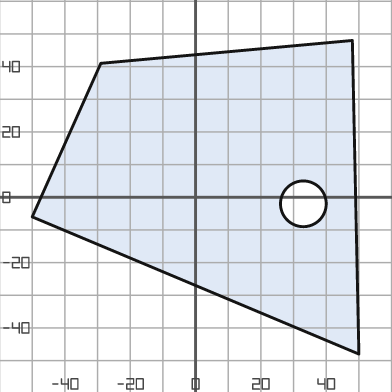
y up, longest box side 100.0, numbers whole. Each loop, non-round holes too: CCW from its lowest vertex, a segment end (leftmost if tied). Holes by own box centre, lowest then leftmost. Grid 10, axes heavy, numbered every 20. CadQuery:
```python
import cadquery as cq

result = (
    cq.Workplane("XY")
    .moveTo(50.0, -48.0)
    .lineTo(48.0, 48.0)
    .lineTo(-29.0, 41.0)
    .lineTo(-50.0, -6.0)
    .close()
    .moveTo(33.0, -2.0)
    .circle(7.0)
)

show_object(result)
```